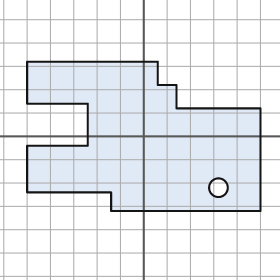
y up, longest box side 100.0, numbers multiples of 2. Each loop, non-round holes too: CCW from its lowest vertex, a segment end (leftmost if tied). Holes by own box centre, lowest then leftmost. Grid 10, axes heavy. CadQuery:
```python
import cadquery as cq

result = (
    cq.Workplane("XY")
    .moveTo(-14.0, -32.0)
    .lineTo(50.0, -32.0)
    .lineTo(50.0, 12.0)
    .lineTo(14.0, 12.0)
    .lineTo(14.0, 22.0)
    .lineTo(6.0, 22.0)
    .lineTo(6.0, 32.0)
    .lineTo(-50.0, 32.0)
    .lineTo(-50.0, 14.0)
    .lineTo(-24.0, 14.0)
    .lineTo(-24.0, -4.0)
    .lineTo(-50.0, -4.0)
    .lineTo(-50.0, -24.0)
    .lineTo(-14.0, -24.0)
    .close()
    .moveTo(32.0, -22.0)
    .circle(4.0)
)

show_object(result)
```